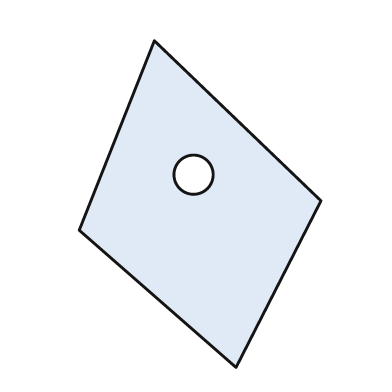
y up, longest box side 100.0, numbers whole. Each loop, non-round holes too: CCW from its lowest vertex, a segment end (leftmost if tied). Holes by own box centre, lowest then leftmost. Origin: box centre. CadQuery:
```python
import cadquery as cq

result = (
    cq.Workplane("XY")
    .moveTo(11.0, -50.0)
    .lineTo(37.0, 1.0)
    .lineTo(-14.0, 50.0)
    .lineTo(-37.0, -8.0)
    .close()
    .moveTo(-2.0, 9.0)
    .circle(6.0)
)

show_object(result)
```